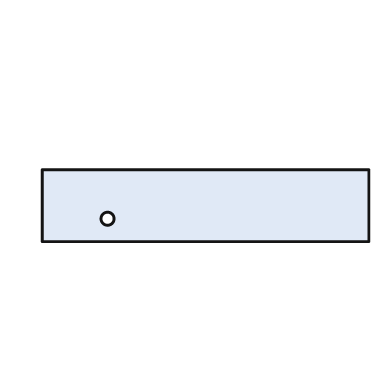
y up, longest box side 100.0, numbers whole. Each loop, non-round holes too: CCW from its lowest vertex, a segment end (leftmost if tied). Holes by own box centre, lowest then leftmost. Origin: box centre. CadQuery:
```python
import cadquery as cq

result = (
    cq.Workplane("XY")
    .moveTo(-50.0, -11.0)
    .lineTo(50.0, -11.0)
    .lineTo(50.0, 11.0)
    .lineTo(-50.0, 11.0)
    .close()
    .moveTo(-30.0, -4.0)
    .circle(2.0)
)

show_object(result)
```